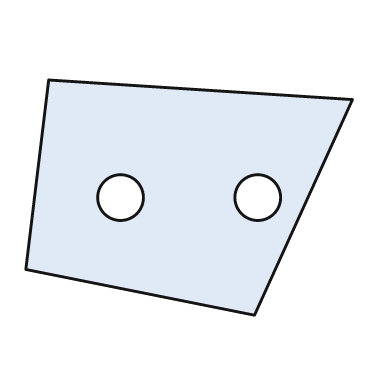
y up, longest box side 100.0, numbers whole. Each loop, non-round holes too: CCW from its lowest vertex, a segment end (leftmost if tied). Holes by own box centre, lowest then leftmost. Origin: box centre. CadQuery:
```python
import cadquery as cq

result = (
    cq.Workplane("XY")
    .moveTo(20.0, -36.0)
    .lineTo(50.0, 30.0)
    .lineTo(-43.0, 36.0)
    .lineTo(-50.0, -22.0)
    .close()
    .moveTo(-21.0, 0.0)
    .circle(7.0)
    .moveTo(21.0, 0.0)
    .circle(7.0)
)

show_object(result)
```